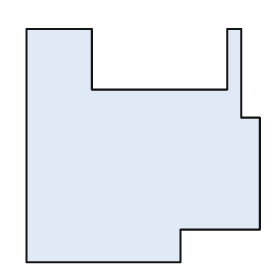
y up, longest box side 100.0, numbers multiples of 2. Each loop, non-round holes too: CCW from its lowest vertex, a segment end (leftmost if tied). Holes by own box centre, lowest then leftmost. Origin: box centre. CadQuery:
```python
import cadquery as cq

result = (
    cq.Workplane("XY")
    .moveTo(-50.0, -50.0)
    .lineTo(16.0, -50.0)
    .lineTo(16.0, -36.0)
    .lineTo(50.0, -36.0)
    .lineTo(50.0, 12.0)
    .lineTo(42.0, 12.0)
    .lineTo(42.0, 50.0)
    .lineTo(36.0, 50.0)
    .lineTo(36.0, 24.0)
    .lineTo(-22.0, 24.0)
    .lineTo(-22.0, 50.0)
    .lineTo(-50.0, 50.0)
    .close()
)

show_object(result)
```